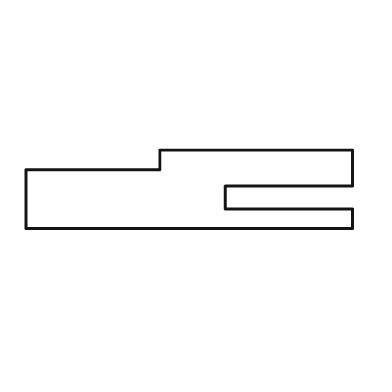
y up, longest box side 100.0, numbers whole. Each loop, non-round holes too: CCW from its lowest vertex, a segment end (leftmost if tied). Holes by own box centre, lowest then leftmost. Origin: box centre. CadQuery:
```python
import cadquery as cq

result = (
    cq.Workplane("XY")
    .moveTo(-50.0, -12.0)
    .lineTo(50.0, -12.0)
    .lineTo(50.0, -6.0)
    .lineTo(11.0, -6.0)
    .lineTo(11.0, 1.0)
    .lineTo(50.0, 1.0)
    .lineTo(50.0, 12.0)
    .lineTo(-9.0, 12.0)
    .lineTo(-9.0, 6.0)
    .lineTo(-50.0, 6.0)
    .close()
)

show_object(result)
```